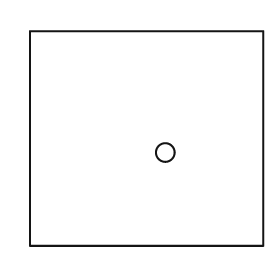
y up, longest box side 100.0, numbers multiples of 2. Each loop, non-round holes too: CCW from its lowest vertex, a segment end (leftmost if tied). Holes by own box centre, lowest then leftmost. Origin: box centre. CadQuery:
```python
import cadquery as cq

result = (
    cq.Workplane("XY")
    .moveTo(-50.0, -46.0)
    .lineTo(50.0, -46.0)
    .lineTo(50.0, 46.0)
    .lineTo(-50.0, 46.0)
    .close()
    .moveTo(8.0, -6.0)
    .circle(4.0)
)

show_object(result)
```